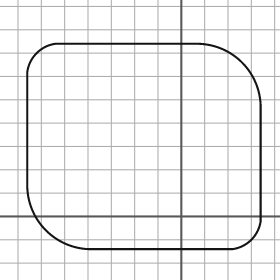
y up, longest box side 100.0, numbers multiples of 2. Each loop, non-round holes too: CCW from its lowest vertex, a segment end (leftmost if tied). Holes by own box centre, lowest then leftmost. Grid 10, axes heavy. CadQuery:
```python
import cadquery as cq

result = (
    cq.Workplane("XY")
    .moveTo(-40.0, -14.0)
    .lineTo(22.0, -14.0)
    .threePointArc((30.0, -10.0), (34.0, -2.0))
    .lineTo(34.0, 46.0)
    .threePointArc((26.0, 66.0), (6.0, 74.0))
    .lineTo(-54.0, 74.0)
    .threePointArc((-62.0, 70.0), (-66.0, 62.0))
    .lineTo(-66.0, 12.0)
    .threePointArc((-58.0, -6.0), (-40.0, -14.0))
    .close()
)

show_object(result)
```